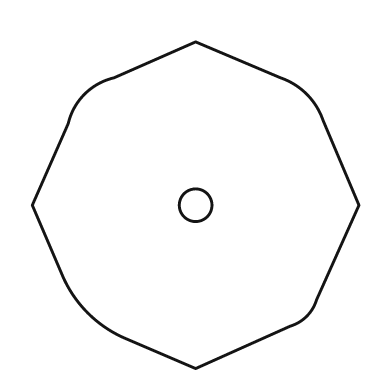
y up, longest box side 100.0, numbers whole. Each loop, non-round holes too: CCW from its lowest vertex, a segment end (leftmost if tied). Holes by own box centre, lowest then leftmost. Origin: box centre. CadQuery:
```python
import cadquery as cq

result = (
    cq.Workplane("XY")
    .moveTo(0.0, -50.0)
    .lineTo(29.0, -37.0)
    .threePointArc((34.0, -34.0), (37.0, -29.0))
    .lineTo(50.0, 0.0)
    .lineTo(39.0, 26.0)
    .threePointArc((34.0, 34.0), (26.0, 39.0))
    .lineTo(0.0, 50.0)
    .lineTo(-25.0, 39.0)
    .threePointArc((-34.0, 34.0), (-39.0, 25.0))
    .lineTo(-50.0, 0.0)
    .lineTo(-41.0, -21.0)
    .threePointArc((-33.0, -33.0), (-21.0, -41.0))
    .close()
    .moveTo(0.0, 0.0)
    .circle(5.0)
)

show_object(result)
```